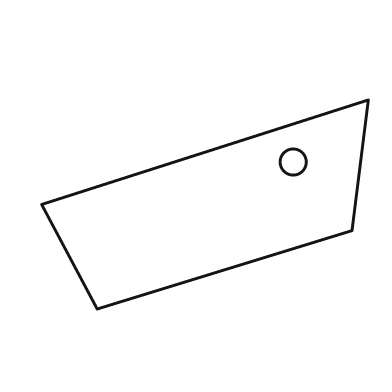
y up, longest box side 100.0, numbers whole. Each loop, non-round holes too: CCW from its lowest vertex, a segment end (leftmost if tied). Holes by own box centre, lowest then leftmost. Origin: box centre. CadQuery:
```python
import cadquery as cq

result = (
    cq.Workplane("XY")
    .moveTo(-33.0, -32.0)
    .lineTo(45.0, -8.0)
    .lineTo(50.0, 32.0)
    .lineTo(-50.0, 0.0)
    .close()
    .moveTo(27.0, 13.0)
    .circle(4.0)
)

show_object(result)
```